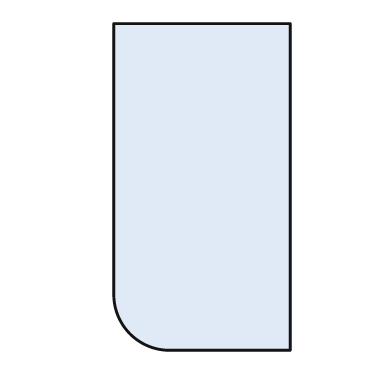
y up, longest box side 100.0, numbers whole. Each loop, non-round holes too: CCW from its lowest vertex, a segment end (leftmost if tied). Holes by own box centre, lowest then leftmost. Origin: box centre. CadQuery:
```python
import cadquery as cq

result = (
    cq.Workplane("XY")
    .moveTo(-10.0, -50.0)
    .lineTo(27.0, -50.0)
    .lineTo(27.0, 50.0)
    .lineTo(-27.0, 50.0)
    .lineTo(-27.0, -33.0)
    .threePointArc((-22.0, -45.0), (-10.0, -50.0))
    .close()
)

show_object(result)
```